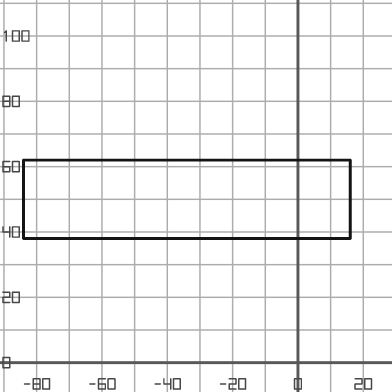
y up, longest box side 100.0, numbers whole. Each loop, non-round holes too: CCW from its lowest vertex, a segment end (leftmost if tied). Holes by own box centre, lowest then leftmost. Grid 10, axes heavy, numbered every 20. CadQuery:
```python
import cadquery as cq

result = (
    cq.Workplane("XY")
    .moveTo(-84.0, 38.0)
    .lineTo(16.0, 38.0)
    .lineTo(16.0, 62.0)
    .lineTo(-84.0, 62.0)
    .close()
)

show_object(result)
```